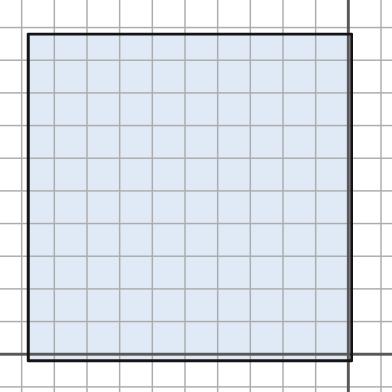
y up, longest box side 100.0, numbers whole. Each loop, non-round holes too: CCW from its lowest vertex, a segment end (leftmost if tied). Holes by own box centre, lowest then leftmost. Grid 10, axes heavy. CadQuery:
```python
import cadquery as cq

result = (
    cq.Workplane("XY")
    .moveTo(-98.0, -2.0)
    .lineTo(1.0, -2.0)
    .lineTo(1.0, 98.0)
    .lineTo(-98.0, 98.0)
    .close()
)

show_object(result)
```